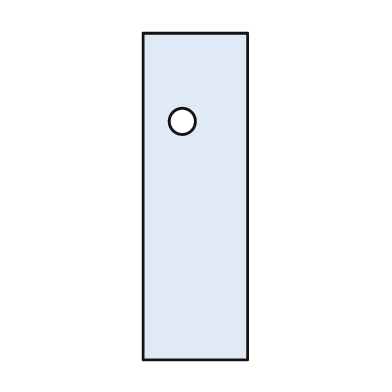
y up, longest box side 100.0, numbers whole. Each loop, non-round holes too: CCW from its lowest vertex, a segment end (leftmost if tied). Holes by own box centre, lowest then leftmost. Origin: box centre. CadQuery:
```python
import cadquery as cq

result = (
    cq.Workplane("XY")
    .moveTo(-16.0, -50.0)
    .lineTo(16.0, -50.0)
    .lineTo(16.0, 50.0)
    .lineTo(-16.0, 50.0)
    .close()
    .moveTo(-4.0, 23.0)
    .circle(4.0)
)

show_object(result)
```